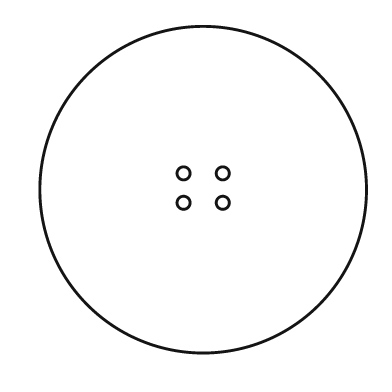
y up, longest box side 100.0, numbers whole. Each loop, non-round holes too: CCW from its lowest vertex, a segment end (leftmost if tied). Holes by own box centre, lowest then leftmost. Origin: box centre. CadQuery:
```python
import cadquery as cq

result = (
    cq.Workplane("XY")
    .moveTo(0.0, 0.0)
    .circle(50.0)
    .moveTo(-6.0, -4.0)
    .circle(2.0)
    .moveTo(6.0, -4.0)
    .circle(2.0)
    .moveTo(-6.0, 5.0)
    .circle(2.0)
    .moveTo(6.0, 5.0)
    .circle(2.0)
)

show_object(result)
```